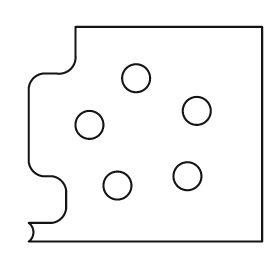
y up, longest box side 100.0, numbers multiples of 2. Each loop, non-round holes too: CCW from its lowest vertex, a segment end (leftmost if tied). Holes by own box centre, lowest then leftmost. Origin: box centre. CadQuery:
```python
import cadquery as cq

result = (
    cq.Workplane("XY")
    .moveTo(-50.0, -46.0)
    .lineTo(50.0, -46.0)
    .lineTo(50.0, 46.0)
    .lineTo(-30.0, 46.0)
    .lineTo(-30.0, 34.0)
    .threePointArc((-32.0, 28.0), (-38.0, 26.0))
    .lineTo(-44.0, 26.0)
    .threePointArc((-48.0, 24.0), (-50.0, 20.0))
    .lineTo(-50.0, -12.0)
    .threePointArc((-48.0, -16.0), (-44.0, -18.0))
    .lineTo(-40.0, -18.0)
    .threePointArc((-36.0, -20.0), (-34.0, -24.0))
    .lineTo(-34.0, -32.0)
    .threePointArc((-36.0, -36.0), (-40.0, -38.0))
    .lineTo(-50.0, -38.0)
    .threePointArc((-48.0, -42.0), (-50.0, -46.0))
    .close()
    .moveTo(-12.0, -22.0)
    .circle(6.0)
    .moveTo(18.0, -18.0)
    .circle(6.0)
    .moveTo(-24.0, 4.0)
    .circle(6.0)
    .moveTo(22.0, 10.0)
    .circle(6.0)
    .moveTo(-4.0, 24.0)
    .circle(6.0)
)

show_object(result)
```